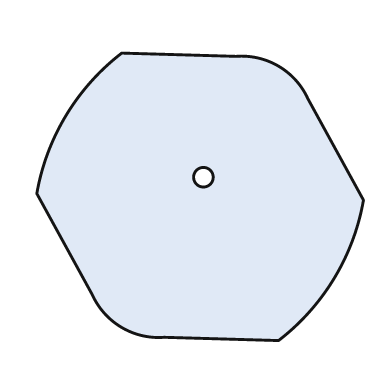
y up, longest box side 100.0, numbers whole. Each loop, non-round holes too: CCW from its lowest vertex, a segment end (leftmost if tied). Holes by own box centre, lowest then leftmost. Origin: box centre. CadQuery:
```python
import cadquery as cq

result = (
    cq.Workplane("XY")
    .moveTo(24.0, -44.0)
    .threePointArc((41.0, -25.0), (50.0, -1.0))
    .lineTo(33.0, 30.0)
    .threePointArc((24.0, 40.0), (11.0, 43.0))
    .lineTo(-24.0, 44.0)
    .threePointArc((-41.0, 25.0), (-50.0, 1.0))
    .lineTo(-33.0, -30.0)
    .threePointArc((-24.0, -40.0), (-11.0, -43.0))
    .close()
    .moveTo(1.0, 6.0)
    .circle(3.0)
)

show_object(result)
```